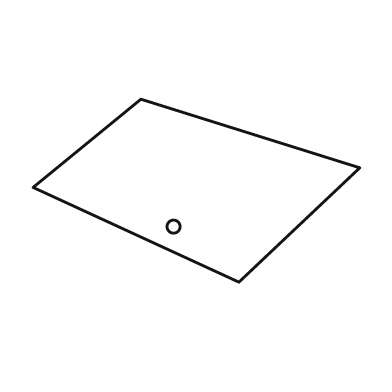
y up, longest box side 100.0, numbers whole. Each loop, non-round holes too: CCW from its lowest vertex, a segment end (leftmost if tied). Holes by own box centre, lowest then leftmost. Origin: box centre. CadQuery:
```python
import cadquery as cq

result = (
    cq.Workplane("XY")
    .moveTo(13.0, -28.0)
    .lineTo(50.0, 7.0)
    .lineTo(-17.0, 28.0)
    .lineTo(-50.0, 1.0)
    .close()
    .moveTo(-7.0, -11.0)
    .circle(2.0)
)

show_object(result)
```